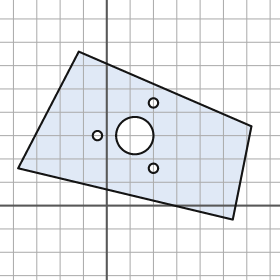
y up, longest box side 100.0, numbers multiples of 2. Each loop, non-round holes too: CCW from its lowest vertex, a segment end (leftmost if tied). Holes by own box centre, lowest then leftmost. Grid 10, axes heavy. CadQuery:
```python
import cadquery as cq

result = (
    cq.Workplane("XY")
    .moveTo(54.0, -6.0)
    .lineTo(62.0, 34.0)
    .lineTo(-12.0, 66.0)
    .lineTo(-38.0, 16.0)
    .close()
    .moveTo(20.0, 16.0)
    .circle(2.0)
    .moveTo(-4.0, 30.0)
    .circle(2.0)
    .moveTo(12.0, 30.0)
    .circle(8.0)
    .moveTo(20.0, 44.0)
    .circle(2.0)
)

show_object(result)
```